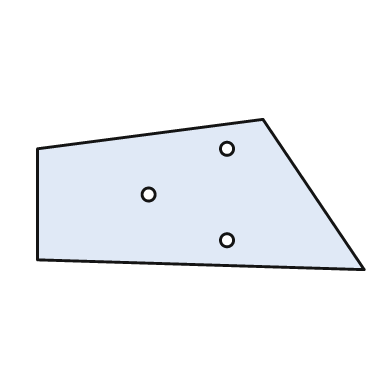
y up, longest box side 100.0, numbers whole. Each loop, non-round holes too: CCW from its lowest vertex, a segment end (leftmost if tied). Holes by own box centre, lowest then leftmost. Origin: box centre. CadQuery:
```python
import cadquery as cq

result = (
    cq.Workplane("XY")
    .moveTo(50.0, -23.0)
    .lineTo(19.0, 23.0)
    .lineTo(-50.0, 14.0)
    .lineTo(-50.0, -20.0)
    .close()
    .moveTo(8.0, -14.0)
    .circle(2.0)
    .moveTo(-16.0, 0.0)
    .circle(2.0)
    .moveTo(8.0, 14.0)
    .circle(2.0)
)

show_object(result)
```